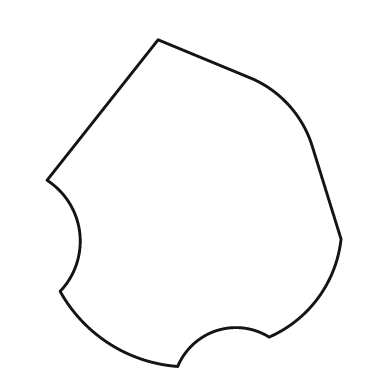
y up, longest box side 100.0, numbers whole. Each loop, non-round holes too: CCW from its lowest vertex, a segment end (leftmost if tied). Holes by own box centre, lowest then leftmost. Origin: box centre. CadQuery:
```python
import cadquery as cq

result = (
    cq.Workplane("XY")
    .moveTo(-5.0, -50.0)
    .threePointArc((7.0, -39.0), (23.0, -41.0))
    .threePointArc((38.0, -29.0), (45.0, -11.0))
    .lineTo(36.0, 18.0)
    .threePointArc((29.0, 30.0), (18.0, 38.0))
    .lineTo(-11.0, 50.0)
    .lineTo(-45.0, 7.0)
    .threePointArc((-35.0, -9.0), (-41.0, -27.0))
    .threePointArc((-26.0, -43.0), (-5.0, -50.0))
    .close()
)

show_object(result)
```